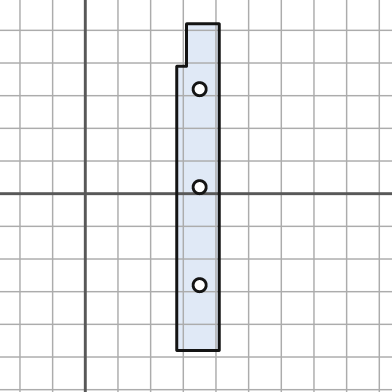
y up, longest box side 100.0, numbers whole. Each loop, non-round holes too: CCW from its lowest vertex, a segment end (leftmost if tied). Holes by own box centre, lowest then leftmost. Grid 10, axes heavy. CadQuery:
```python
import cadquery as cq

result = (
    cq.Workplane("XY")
    .moveTo(28.0, -48.0)
    .lineTo(41.0, -48.0)
    .lineTo(41.0, 52.0)
    .lineTo(31.0, 52.0)
    .lineTo(31.0, 39.0)
    .lineTo(28.0, 39.0)
    .close()
    .moveTo(35.0, -28.0)
    .circle(2.0)
    .moveTo(35.0, 2.0)
    .circle(2.0)
    .moveTo(35.0, 32.0)
    .circle(2.0)
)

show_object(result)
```